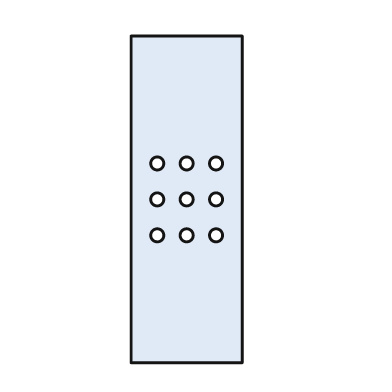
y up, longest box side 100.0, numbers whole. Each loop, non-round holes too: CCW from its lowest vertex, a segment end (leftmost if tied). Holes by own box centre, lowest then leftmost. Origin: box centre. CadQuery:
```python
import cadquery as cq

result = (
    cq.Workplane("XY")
    .moveTo(-17.0, -50.0)
    .lineTo(17.0, -50.0)
    .lineTo(17.0, 50.0)
    .lineTo(-17.0, 50.0)
    .close()
    .moveTo(-9.0, -11.0)
    .circle(2.0)
    .moveTo(0.0, -11.0)
    .circle(2.0)
    .moveTo(9.0, -11.0)
    .circle(2.0)
    .moveTo(-9.0, 0.0)
    .circle(2.0)
    .moveTo(0.0, 0.0)
    .circle(2.0)
    .moveTo(9.0, 0.0)
    .circle(2.0)
    .moveTo(-9.0, 11.0)
    .circle(2.0)
    .moveTo(0.0, 11.0)
    .circle(2.0)
    .moveTo(9.0, 11.0)
    .circle(2.0)
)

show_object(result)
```